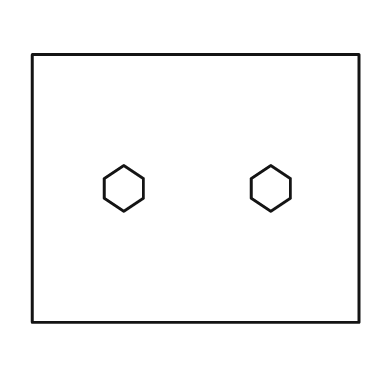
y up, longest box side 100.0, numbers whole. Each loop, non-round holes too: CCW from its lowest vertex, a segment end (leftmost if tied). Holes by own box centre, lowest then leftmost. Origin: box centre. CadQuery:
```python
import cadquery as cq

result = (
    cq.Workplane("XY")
    .moveTo(-50.0, -41.0)
    .lineTo(50.0, -41.0)
    .lineTo(50.0, 41.0)
    .lineTo(-50.0, 41.0)
    .close()
    .moveTo(-22.0, -7.0)
    .lineTo(-16.0, -3.0)
    .lineTo(-16.0, 3.0)
    .lineTo(-22.0, 7.0)
    .lineTo(-28.0, 3.0)
    .lineTo(-28.0, -3.0)
    .close()
    .moveTo(23.0, -7.0)
    .lineTo(29.0, -3.0)
    .lineTo(29.0, 3.0)
    .lineTo(23.0, 7.0)
    .lineTo(17.0, 3.0)
    .lineTo(17.0, -3.0)
    .close()
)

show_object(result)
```